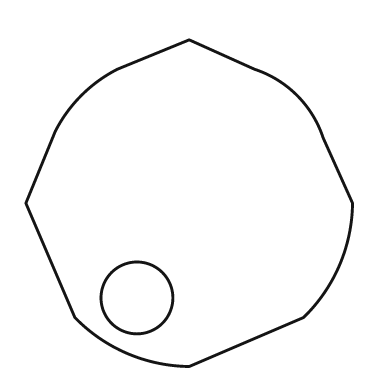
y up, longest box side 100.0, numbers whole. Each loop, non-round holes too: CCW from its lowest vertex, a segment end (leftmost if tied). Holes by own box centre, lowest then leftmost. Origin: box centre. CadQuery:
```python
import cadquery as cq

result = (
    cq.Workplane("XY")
    .moveTo(0.0, -50.0)
    .lineTo(35.0, -35.0)
    .threePointArc((46.0, -19.0), (50.0, 0.0))
    .lineTo(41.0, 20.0)
    .threePointArc((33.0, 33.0), (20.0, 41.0))
    .lineTo(0.0, 50.0)
    .lineTo(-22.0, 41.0)
    .threePointArc((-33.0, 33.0), (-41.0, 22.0))
    .lineTo(-50.0, 0.0)
    .lineTo(-35.0, -35.0)
    .threePointArc((-19.0, -46.0), (0.0, -50.0))
    .close()
    .moveTo(-16.0, -29.0)
    .circle(11.0)
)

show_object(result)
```